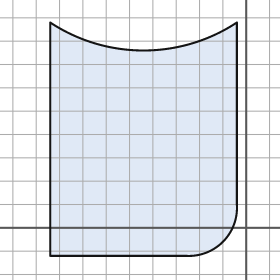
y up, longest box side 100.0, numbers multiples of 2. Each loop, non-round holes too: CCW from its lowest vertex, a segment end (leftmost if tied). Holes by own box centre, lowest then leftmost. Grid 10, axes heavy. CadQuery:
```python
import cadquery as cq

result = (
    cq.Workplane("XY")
    .moveTo(-84.0, -12.0)
    .lineTo(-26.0, -12.0)
    .threePointArc((-10.0, -6.0), (-4.0, 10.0))
    .lineTo(-4.0, 88.0)
    .threePointArc((-44.0, 76.0), (-84.0, 88.0))
    .close()
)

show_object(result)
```